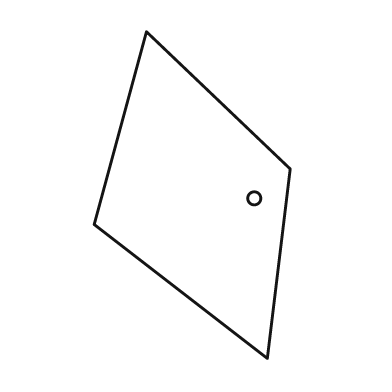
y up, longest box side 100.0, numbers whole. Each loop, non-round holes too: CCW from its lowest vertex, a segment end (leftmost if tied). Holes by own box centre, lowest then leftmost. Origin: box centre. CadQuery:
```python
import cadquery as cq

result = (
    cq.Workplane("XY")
    .moveTo(23.0, -50.0)
    .lineTo(30.0, 8.0)
    .lineTo(-14.0, 50.0)
    .lineTo(-30.0, -9.0)
    .close()
    .moveTo(19.0, -1.0)
    .circle(2.0)
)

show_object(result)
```